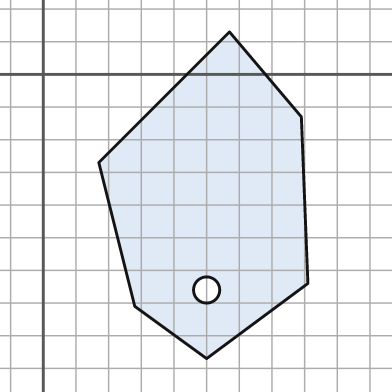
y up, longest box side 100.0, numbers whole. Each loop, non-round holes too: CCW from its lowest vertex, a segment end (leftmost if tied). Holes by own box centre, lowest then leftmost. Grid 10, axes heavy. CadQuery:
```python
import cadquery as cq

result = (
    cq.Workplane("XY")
    .moveTo(50.0, -87.0)
    .lineTo(81.0, -64.0)
    .lineTo(79.0, -13.0)
    .lineTo(57.0, 13.0)
    .lineTo(17.0, -27.0)
    .lineTo(28.0, -71.0)
    .close()
    .moveTo(50.0, -66.0)
    .circle(4.0)
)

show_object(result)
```